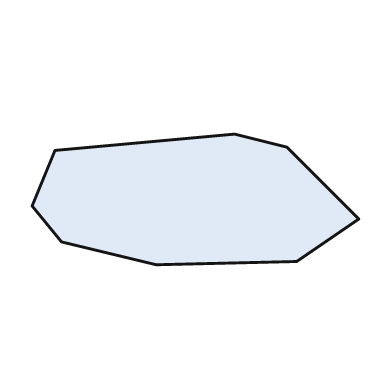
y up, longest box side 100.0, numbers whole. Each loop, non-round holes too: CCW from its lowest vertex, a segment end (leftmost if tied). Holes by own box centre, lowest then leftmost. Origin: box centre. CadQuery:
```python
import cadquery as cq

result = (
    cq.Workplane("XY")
    .moveTo(-12.0, -20.0)
    .lineTo(31.0, -19.0)
    .lineTo(50.0, -6.0)
    .lineTo(28.0, 16.0)
    .lineTo(12.0, 20.0)
    .lineTo(-43.0, 15.0)
    .lineTo(-50.0, -2.0)
    .lineTo(-41.0, -13.0)
    .close()
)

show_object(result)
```